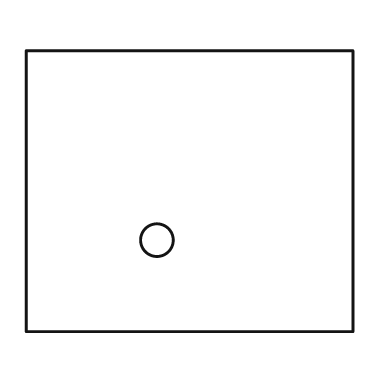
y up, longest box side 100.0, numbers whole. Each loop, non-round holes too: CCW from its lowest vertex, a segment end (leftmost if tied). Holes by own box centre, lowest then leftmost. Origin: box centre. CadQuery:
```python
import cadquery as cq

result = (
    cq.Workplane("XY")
    .moveTo(-50.0, -43.0)
    .lineTo(50.0, -43.0)
    .lineTo(50.0, 43.0)
    .lineTo(-50.0, 43.0)
    .close()
    .moveTo(-10.0, -15.0)
    .circle(5.0)
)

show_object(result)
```